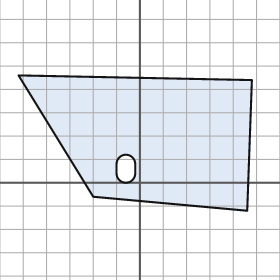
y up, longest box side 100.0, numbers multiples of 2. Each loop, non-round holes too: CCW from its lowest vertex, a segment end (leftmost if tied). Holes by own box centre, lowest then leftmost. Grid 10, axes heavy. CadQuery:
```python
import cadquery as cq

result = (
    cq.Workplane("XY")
    .moveTo(46.0, -12.0)
    .lineTo(48.0, 44.0)
    .lineTo(-52.0, 46.0)
    .lineTo(-20.0, -6.0)
    .close()
    .moveTo(-10.0, 4.0)
    .threePointArc((-6.0, 0.0), (-2.0, 4.0))
    .lineTo(-2.0, 8.0)
    .threePointArc((-6.0, 12.0), (-10.0, 8.0))
    .close()
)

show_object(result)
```